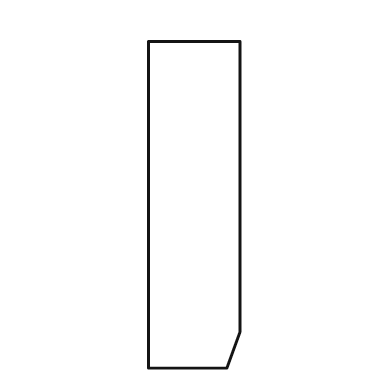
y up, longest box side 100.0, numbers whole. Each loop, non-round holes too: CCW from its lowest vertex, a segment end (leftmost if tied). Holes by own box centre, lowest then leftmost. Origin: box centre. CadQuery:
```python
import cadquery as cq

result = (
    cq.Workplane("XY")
    .moveTo(-14.0, -50.0)
    .lineTo(10.0, -50.0)
    .lineTo(14.0, -39.0)
    .lineTo(14.0, 50.0)
    .lineTo(-14.0, 50.0)
    .close()
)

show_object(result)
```